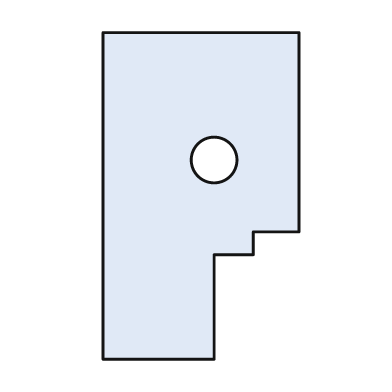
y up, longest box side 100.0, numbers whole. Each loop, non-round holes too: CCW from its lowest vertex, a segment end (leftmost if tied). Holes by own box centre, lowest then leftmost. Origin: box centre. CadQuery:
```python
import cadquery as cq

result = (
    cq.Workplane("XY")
    .moveTo(-30.0, -50.0)
    .lineTo(4.0, -50.0)
    .lineTo(4.0, -18.0)
    .lineTo(16.0, -18.0)
    .lineTo(16.0, -11.0)
    .lineTo(30.0, -11.0)
    .lineTo(30.0, 50.0)
    .lineTo(-30.0, 50.0)
    .close()
    .moveTo(4.0, 11.0)
    .circle(7.0)
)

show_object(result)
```